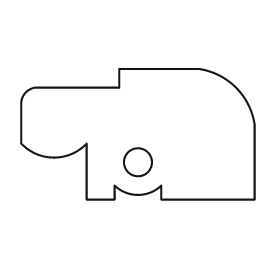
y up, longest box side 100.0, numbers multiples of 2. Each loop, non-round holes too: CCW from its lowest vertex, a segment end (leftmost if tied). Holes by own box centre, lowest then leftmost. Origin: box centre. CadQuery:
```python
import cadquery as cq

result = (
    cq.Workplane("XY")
    .moveTo(-22.0, -28.0)
    .lineTo(-10.0, -28.0)
    .lineTo(-10.0, -22.0)
    .threePointArc((0.0, -26.0), (10.0, -22.0))
    .lineTo(10.0, -28.0)
    .lineTo(50.0, -28.0)
    .lineTo(50.0, 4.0)
    .threePointArc((42.0, 20.0), (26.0, 28.0))
    .lineTo(-8.0, 28.0)
    .lineTo(-8.0, 20.0)
    .lineTo(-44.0, 20.0)
    .threePointArc((-48.0, 18.0), (-50.0, 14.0))
    .lineTo(-50.0, -4.0)
    .threePointArc((-36.0, -10.0), (-22.0, -4.0))
    .close()
    .moveTo(0.0, -12.0)
    .circle(6.0)
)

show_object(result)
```